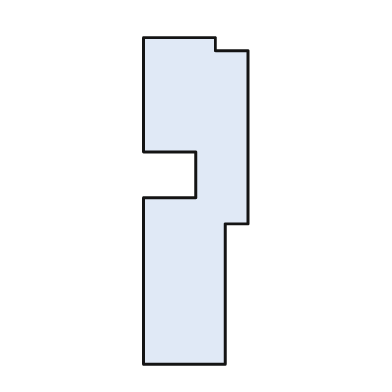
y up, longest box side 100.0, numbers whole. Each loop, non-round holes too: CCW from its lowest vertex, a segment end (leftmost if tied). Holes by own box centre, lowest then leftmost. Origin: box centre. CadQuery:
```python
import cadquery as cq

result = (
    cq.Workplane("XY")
    .moveTo(-16.0, -50.0)
    .lineTo(9.0, -50.0)
    .lineTo(9.0, -7.0)
    .lineTo(16.0, -7.0)
    .lineTo(16.0, 46.0)
    .lineTo(6.0, 46.0)
    .lineTo(6.0, 50.0)
    .lineTo(-16.0, 50.0)
    .lineTo(-16.0, 15.0)
    .lineTo(0.0, 15.0)
    .lineTo(0.0, 1.0)
    .lineTo(-16.0, 1.0)
    .close()
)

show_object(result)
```